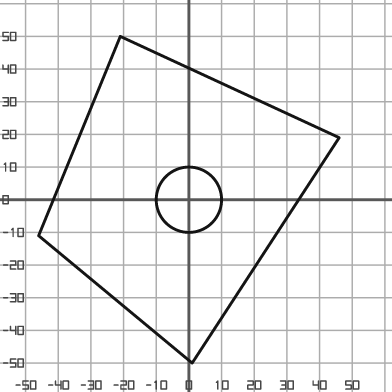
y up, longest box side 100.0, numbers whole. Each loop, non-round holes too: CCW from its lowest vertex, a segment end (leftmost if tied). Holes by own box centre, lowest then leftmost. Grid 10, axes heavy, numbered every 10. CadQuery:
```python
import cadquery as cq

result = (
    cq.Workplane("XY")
    .moveTo(1.0, -50.0)
    .lineTo(46.0, 19.0)
    .lineTo(-21.0, 50.0)
    .lineTo(-46.0, -11.0)
    .close()
    .moveTo(0.0, 0.0)
    .circle(10.0)
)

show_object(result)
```